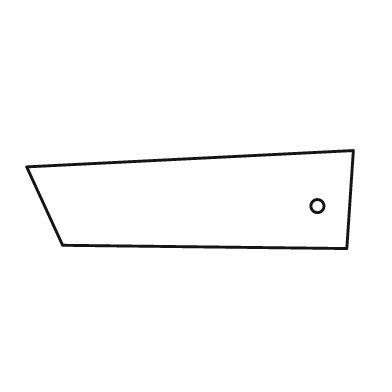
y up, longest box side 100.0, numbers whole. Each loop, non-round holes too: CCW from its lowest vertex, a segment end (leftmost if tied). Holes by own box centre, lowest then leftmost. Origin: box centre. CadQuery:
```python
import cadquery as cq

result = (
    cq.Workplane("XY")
    .moveTo(48.0, -15.0)
    .lineTo(50.0, 15.0)
    .lineTo(-50.0, 10.0)
    .lineTo(-39.0, -14.0)
    .close()
    .moveTo(39.0, -2.0)
    .circle(2.0)
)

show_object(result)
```